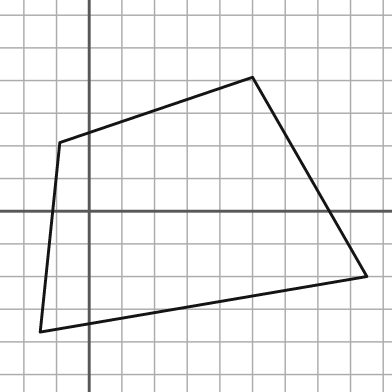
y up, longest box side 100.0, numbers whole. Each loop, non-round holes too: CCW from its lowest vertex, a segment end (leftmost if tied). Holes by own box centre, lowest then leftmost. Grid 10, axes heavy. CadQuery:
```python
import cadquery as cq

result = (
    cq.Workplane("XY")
    .moveTo(-15.0, -37.0)
    .lineTo(85.0, -20.0)
    .lineTo(50.0, 41.0)
    .lineTo(-9.0, 21.0)
    .close()
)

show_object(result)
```